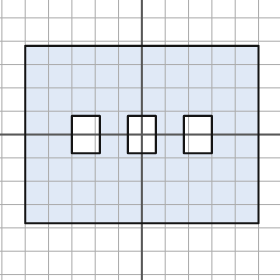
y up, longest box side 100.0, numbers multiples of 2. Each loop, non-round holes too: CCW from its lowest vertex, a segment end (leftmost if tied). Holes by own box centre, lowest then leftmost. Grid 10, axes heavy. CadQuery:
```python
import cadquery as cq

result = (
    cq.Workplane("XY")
    .moveTo(-50.0, -38.0)
    .lineTo(50.0, -38.0)
    .lineTo(50.0, 38.0)
    .lineTo(-50.0, 38.0)
    .close()
    .moveTo(-30.0, -8.0)
    .lineTo(-18.0, -8.0)
    .lineTo(-18.0, 8.0)
    .lineTo(-30.0, 8.0)
    .close()
    .moveTo(-6.0, -8.0)
    .lineTo(6.0, -8.0)
    .lineTo(6.0, 8.0)
    .lineTo(-6.0, 8.0)
    .close()
    .moveTo(18.0, -8.0)
    .lineTo(30.0, -8.0)
    .lineTo(30.0, 8.0)
    .lineTo(18.0, 8.0)
    .close()
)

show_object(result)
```